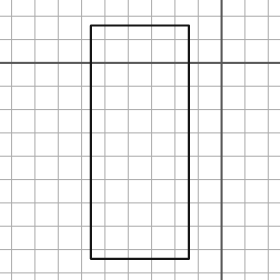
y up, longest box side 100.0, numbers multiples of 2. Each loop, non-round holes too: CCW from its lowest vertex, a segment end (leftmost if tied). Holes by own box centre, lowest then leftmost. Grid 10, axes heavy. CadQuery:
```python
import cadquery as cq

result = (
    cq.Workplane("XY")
    .moveTo(-56.0, -84.0)
    .lineTo(-14.0, -84.0)
    .lineTo(-14.0, 16.0)
    .lineTo(-56.0, 16.0)
    .close()
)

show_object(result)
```